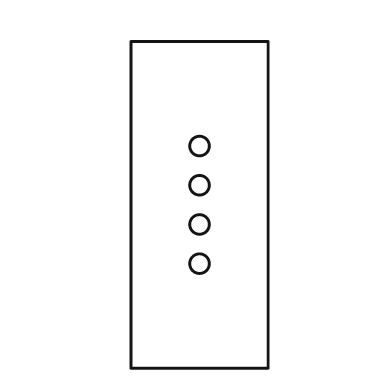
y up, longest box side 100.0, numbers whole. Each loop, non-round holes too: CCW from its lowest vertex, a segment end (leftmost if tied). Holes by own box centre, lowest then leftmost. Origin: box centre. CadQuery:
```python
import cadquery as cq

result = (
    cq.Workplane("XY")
    .moveTo(-21.0, -50.0)
    .lineTo(21.0, -50.0)
    .lineTo(21.0, 50.0)
    .lineTo(-21.0, 50.0)
    .close()
    .moveTo(0.0, -18.0)
    .circle(3.0)
    .moveTo(0.0, -6.0)
    .circle(3.0)
    .moveTo(0.0, 6.0)
    .circle(3.0)
    .moveTo(0.0, 18.0)
    .circle(3.0)
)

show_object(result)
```